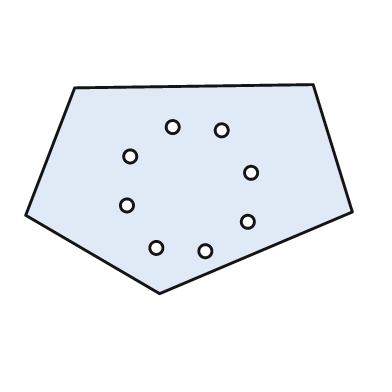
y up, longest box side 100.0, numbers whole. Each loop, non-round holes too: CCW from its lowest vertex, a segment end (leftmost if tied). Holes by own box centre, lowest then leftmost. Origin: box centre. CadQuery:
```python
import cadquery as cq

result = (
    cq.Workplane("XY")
    .moveTo(-9.0, -32.0)
    .lineTo(50.0, -7.0)
    .lineTo(38.0, 32.0)
    .lineTo(-35.0, 31.0)
    .lineTo(-50.0, -8.0)
    .close()
    .moveTo(5.0, -19.0)
    .circle(2.0)
    .moveTo(-10.0, -18.0)
    .circle(2.0)
    .moveTo(18.0, -10.0)
    .circle(2.0)
    .moveTo(-19.0, -5.0)
    .circle(2.0)
    .moveTo(19.0, 5.0)
    .circle(2.0)
    .moveTo(-18.0, 10.0)
    .circle(2.0)
    .moveTo(10.0, 18.0)
    .circle(2.0)
    .moveTo(-5.0, 19.0)
    .circle(2.0)
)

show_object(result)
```